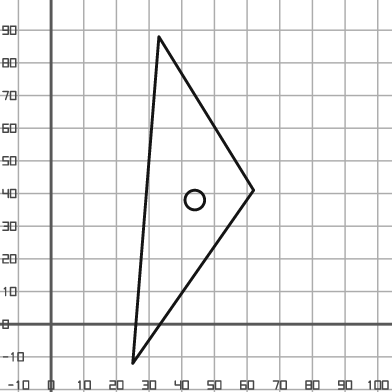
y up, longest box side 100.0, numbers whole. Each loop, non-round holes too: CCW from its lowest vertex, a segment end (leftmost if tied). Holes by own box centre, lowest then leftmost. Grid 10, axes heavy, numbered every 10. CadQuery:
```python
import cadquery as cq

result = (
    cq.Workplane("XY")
    .moveTo(25.0, -12.0)
    .lineTo(62.0, 41.0)
    .lineTo(33.0, 88.0)
    .close()
    .moveTo(44.0, 38.0)
    .circle(3.0)
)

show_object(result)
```